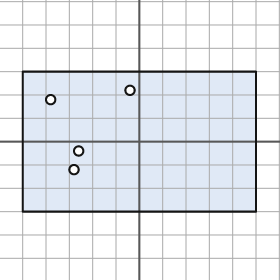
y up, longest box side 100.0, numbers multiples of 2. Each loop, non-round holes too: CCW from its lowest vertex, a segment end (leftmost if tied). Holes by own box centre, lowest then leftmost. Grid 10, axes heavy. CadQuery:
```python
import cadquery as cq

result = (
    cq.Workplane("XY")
    .moveTo(-50.0, -30.0)
    .lineTo(50.0, -30.0)
    .lineTo(50.0, 30.0)
    .lineTo(-50.0, 30.0)
    .close()
    .moveTo(-28.0, -12.0)
    .circle(2.0)
    .moveTo(-26.0, -4.0)
    .circle(2.0)
    .moveTo(-38.0, 18.0)
    .circle(2.0)
    .moveTo(-4.0, 22.0)
    .circle(2.0)
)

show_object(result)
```